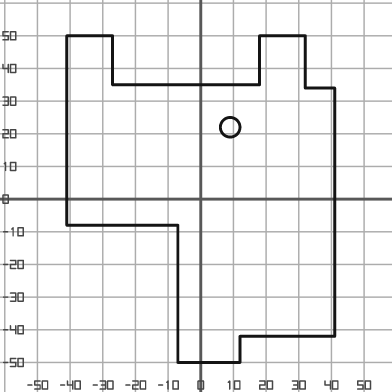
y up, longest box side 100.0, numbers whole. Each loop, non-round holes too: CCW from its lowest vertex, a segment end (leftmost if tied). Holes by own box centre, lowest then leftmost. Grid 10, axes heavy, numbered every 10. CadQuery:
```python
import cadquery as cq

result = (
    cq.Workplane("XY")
    .moveTo(-7.0, -50.0)
    .lineTo(12.0, -50.0)
    .lineTo(12.0, -42.0)
    .lineTo(41.0, -42.0)
    .lineTo(41.0, 34.0)
    .lineTo(32.0, 34.0)
    .lineTo(32.0, 50.0)
    .lineTo(18.0, 50.0)
    .lineTo(18.0, 35.0)
    .lineTo(-27.0, 35.0)
    .lineTo(-27.0, 50.0)
    .lineTo(-41.0, 50.0)
    .lineTo(-41.0, -8.0)
    .lineTo(-7.0, -8.0)
    .close()
    .moveTo(9.0, 22.0)
    .circle(3.0)
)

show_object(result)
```